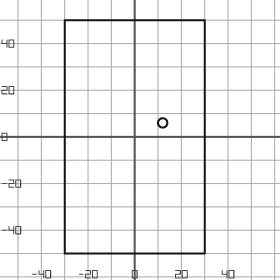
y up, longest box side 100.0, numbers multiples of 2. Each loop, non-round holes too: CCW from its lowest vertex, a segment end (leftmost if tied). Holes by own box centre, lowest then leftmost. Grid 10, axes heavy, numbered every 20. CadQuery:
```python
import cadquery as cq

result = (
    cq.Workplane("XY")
    .moveTo(-30.0, -50.0)
    .lineTo(30.0, -50.0)
    .lineTo(30.0, 50.0)
    .lineTo(-30.0, 50.0)
    .close()
    .moveTo(12.0, 6.0)
    .circle(2.0)
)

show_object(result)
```